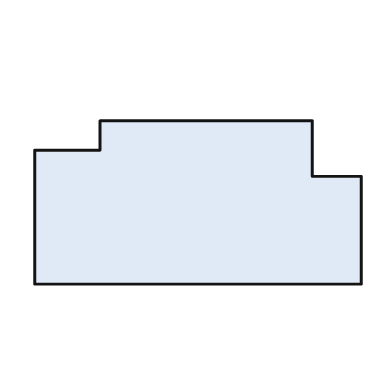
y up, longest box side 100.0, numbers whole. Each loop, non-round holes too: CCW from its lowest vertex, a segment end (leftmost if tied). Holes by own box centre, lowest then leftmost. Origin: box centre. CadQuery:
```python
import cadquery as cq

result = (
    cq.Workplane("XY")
    .moveTo(-50.0, -25.0)
    .lineTo(50.0, -25.0)
    .lineTo(50.0, 8.0)
    .lineTo(35.0, 8.0)
    .lineTo(35.0, 25.0)
    .lineTo(-30.0, 25.0)
    .lineTo(-30.0, 16.0)
    .lineTo(-50.0, 16.0)
    .close()
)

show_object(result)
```